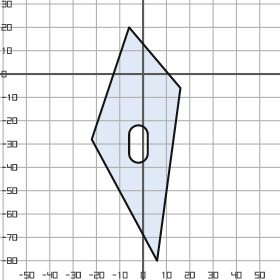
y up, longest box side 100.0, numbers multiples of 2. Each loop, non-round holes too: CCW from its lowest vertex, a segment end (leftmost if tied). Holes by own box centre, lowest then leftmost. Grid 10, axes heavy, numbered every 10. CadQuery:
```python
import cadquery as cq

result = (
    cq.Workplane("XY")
    .moveTo(6.0, -80.0)
    .lineTo(16.0, -6.0)
    .lineTo(-6.0, 20.0)
    .lineTo(-22.0, -28.0)
    .close()
    .moveTo(-6.0, -34.0)
    .threePointArc((-2.0, -38.0), (2.0, -34.0))
    .lineTo(2.0, -26.0)
    .threePointArc((-2.0, -22.0), (-6.0, -26.0))
    .close()
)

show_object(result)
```